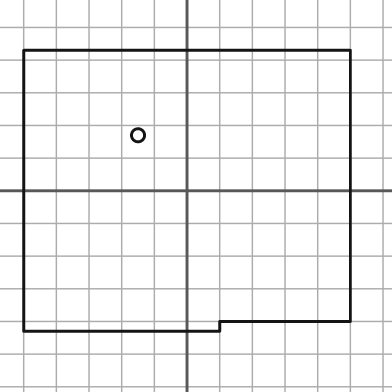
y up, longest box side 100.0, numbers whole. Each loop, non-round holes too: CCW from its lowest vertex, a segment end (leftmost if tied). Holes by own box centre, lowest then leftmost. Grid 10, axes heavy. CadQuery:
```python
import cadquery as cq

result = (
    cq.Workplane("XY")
    .moveTo(-50.0, -43.0)
    .lineTo(10.0, -43.0)
    .lineTo(10.0, -40.0)
    .lineTo(50.0, -40.0)
    .lineTo(50.0, 43.0)
    .lineTo(-50.0, 43.0)
    .close()
    .moveTo(-15.0, 17.0)
    .circle(2.0)
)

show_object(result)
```